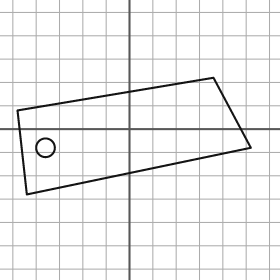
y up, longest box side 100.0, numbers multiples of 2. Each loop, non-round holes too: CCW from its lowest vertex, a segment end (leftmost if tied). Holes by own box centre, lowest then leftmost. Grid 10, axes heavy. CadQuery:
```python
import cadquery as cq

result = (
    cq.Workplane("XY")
    .moveTo(-44.0, -28.0)
    .lineTo(52.0, -8.0)
    .lineTo(36.0, 22.0)
    .lineTo(-48.0, 8.0)
    .close()
    .moveTo(-36.0, -8.0)
    .circle(4.0)
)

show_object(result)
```